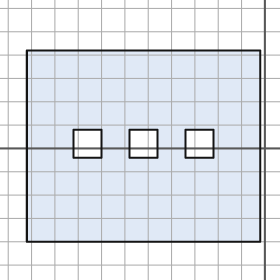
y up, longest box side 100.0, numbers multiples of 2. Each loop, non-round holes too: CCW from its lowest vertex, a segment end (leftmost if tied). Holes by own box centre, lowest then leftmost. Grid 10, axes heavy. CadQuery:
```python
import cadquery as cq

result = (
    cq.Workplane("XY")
    .moveTo(-102.0, -40.0)
    .lineTo(-2.0, -40.0)
    .lineTo(-2.0, 42.0)
    .lineTo(-102.0, 42.0)
    .close()
    .moveTo(-82.0, -4.0)
    .lineTo(-70.0, -4.0)
    .lineTo(-70.0, 8.0)
    .lineTo(-82.0, 8.0)
    .close()
    .moveTo(-58.0, -4.0)
    .lineTo(-46.0, -4.0)
    .lineTo(-46.0, 8.0)
    .lineTo(-58.0, 8.0)
    .close()
    .moveTo(-34.0, -4.0)
    .lineTo(-22.0, -4.0)
    .lineTo(-22.0, 8.0)
    .lineTo(-34.0, 8.0)
    .close()
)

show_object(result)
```